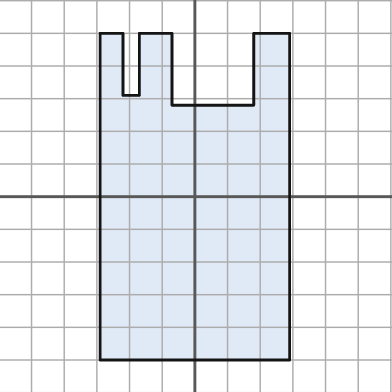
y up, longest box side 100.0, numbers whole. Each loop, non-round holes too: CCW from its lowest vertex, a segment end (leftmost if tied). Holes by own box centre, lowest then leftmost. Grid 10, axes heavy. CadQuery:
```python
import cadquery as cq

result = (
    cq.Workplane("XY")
    .moveTo(-29.0, -50.0)
    .lineTo(29.0, -50.0)
    .lineTo(29.0, 50.0)
    .lineTo(18.0, 50.0)
    .lineTo(18.0, 28.0)
    .lineTo(-7.0, 28.0)
    .lineTo(-7.0, 50.0)
    .lineTo(-17.0, 50.0)
    .lineTo(-17.0, 31.0)
    .lineTo(-22.0, 31.0)
    .lineTo(-22.0, 50.0)
    .lineTo(-29.0, 50.0)
    .close()
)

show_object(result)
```